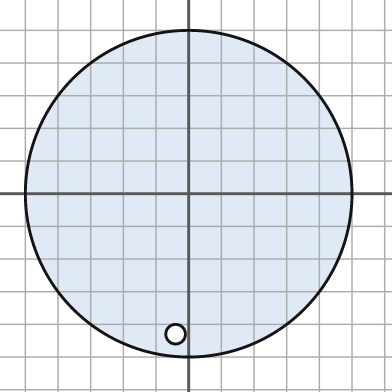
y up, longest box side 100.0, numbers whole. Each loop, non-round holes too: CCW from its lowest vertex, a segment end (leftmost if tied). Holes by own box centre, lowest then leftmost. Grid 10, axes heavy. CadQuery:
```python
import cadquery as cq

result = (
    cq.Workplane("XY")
    .moveTo(0.0, 0.0)
    .circle(50.0)
    .moveTo(-4.0, -43.0)
    .circle(3.0)
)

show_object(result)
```